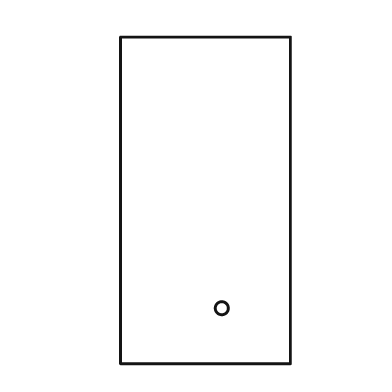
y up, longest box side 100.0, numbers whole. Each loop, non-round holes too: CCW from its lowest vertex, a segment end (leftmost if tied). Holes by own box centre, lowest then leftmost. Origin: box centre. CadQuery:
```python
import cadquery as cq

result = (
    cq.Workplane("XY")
    .moveTo(-26.0, -50.0)
    .lineTo(26.0, -50.0)
    .lineTo(26.0, 50.0)
    .lineTo(-26.0, 50.0)
    .close()
    .moveTo(5.0, -33.0)
    .circle(2.0)
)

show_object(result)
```